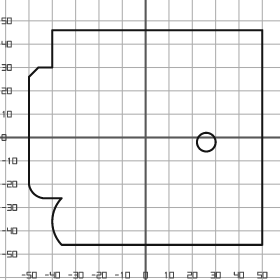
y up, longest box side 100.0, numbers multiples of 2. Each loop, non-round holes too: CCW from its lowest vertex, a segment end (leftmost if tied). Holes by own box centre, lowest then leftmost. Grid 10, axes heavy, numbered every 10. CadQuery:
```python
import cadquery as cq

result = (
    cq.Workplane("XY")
    .moveTo(-36.0, -46.0)
    .lineTo(50.0, -46.0)
    .lineTo(50.0, 46.0)
    .lineTo(-40.0, 46.0)
    .lineTo(-40.0, 30.0)
    .lineTo(-46.0, 30.0)
    .lineTo(-50.0, 26.0)
    .lineTo(-50.0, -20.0)
    .threePointArc((-48.0, -24.0), (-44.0, -26.0))
    .lineTo(-36.0, -26.0)
    .threePointArc((-40.0, -36.0), (-36.0, -46.0))
    .close()
    .moveTo(26.0, -2.0)
    .circle(4.0)
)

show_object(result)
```